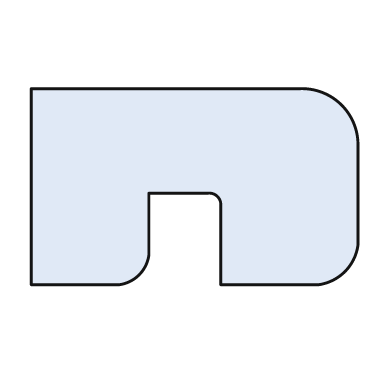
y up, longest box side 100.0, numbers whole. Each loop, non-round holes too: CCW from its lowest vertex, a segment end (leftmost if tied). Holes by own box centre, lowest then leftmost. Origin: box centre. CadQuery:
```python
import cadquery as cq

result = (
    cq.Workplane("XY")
    .moveTo(-50.0, -30.0)
    .lineTo(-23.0, -30.0)
    .threePointArc((-17.0, -27.0), (-14.0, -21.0))
    .lineTo(-14.0, -2.0)
    .lineTo(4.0, -2.0)
    .threePointArc((7.0, -3.0), (8.0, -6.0))
    .lineTo(8.0, -30.0)
    .lineTo(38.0, -30.0)
    .threePointArc((46.0, -26.0), (50.0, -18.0))
    .lineTo(50.0, 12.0)
    .threePointArc((45.0, 25.0), (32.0, 30.0))
    .lineTo(-50.0, 30.0)
    .close()
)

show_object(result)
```